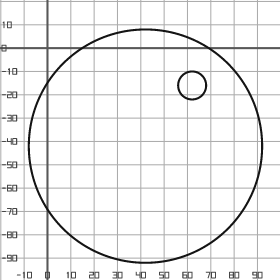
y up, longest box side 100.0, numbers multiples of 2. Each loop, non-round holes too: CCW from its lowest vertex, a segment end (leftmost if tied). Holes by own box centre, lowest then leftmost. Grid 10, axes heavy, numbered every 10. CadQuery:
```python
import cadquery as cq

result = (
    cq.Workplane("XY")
    .moveTo(42.0, -42.0)
    .circle(50.0)
    .moveTo(62.0, -16.0)
    .circle(6.0)
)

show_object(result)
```